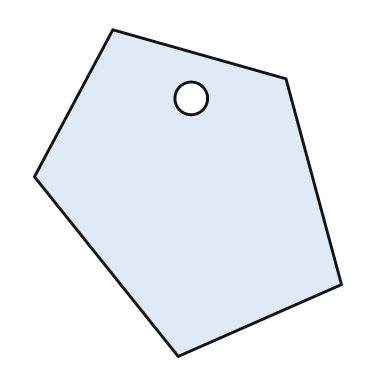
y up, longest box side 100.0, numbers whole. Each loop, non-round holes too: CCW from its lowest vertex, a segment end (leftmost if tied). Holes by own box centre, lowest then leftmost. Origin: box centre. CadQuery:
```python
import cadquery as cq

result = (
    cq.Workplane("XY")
    .moveTo(-3.0, -50.0)
    .lineTo(47.0, -28.0)
    .lineTo(30.0, 35.0)
    .lineTo(-23.0, 50.0)
    .lineTo(-47.0, 5.0)
    .close()
    .moveTo(1.0, 29.0)
    .circle(5.0)
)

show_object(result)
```